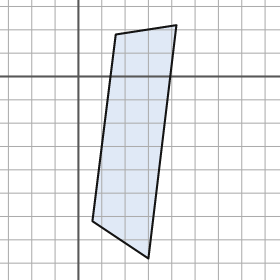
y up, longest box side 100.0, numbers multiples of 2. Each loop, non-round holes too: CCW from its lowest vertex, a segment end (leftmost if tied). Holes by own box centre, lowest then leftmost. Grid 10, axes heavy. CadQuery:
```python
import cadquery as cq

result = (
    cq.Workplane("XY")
    .moveTo(30.0, -78.0)
    .lineTo(42.0, 22.0)
    .lineTo(16.0, 18.0)
    .lineTo(6.0, -62.0)
    .close()
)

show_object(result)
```